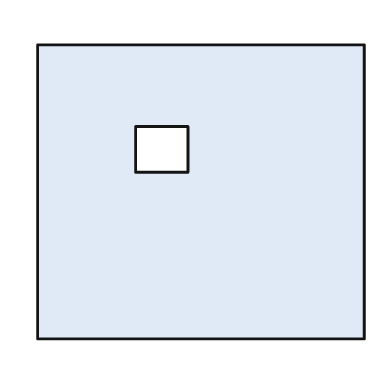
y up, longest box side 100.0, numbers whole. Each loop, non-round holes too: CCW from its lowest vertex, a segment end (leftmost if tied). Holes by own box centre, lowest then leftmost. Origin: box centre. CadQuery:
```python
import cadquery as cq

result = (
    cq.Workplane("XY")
    .moveTo(-50.0, -45.0)
    .lineTo(50.0, -45.0)
    .lineTo(50.0, 45.0)
    .lineTo(-50.0, 45.0)
    .close()
    .moveTo(-20.0, 6.0)
    .lineTo(-4.0, 6.0)
    .lineTo(-4.0, 20.0)
    .lineTo(-20.0, 20.0)
    .close()
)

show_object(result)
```